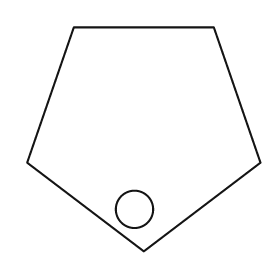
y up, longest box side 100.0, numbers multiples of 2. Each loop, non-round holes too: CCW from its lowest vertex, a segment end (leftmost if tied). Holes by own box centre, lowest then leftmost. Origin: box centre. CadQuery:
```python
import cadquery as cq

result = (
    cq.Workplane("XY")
    .moveTo(0.0, -48.0)
    .lineTo(50.0, -10.0)
    .lineTo(30.0, 48.0)
    .lineTo(-30.0, 48.0)
    .lineTo(-50.0, -10.0)
    .close()
    .moveTo(-4.0, -30.0)
    .circle(8.0)
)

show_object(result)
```